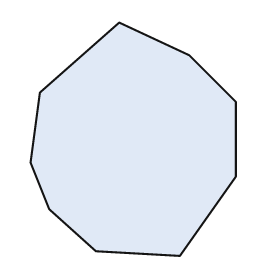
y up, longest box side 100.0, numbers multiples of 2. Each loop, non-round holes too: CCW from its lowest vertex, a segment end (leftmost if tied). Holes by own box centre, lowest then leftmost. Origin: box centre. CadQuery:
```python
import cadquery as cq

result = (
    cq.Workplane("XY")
    .moveTo(20.0, -50.0)
    .lineTo(44.0, -16.0)
    .lineTo(44.0, 16.0)
    .lineTo(24.0, 36.0)
    .lineTo(-6.0, 50.0)
    .lineTo(-40.0, 20.0)
    .lineTo(-44.0, -10.0)
    .lineTo(-36.0, -30.0)
    .lineTo(-16.0, -48.0)
    .close()
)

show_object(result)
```